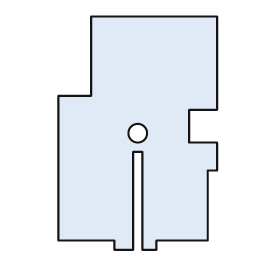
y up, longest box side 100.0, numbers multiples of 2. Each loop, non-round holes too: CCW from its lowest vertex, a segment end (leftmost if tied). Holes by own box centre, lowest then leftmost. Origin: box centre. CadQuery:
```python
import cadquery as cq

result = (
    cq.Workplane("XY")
    .moveTo(-10.0, -50.0)
    .lineTo(-2.0, -50.0)
    .lineTo(-2.0, -8.0)
    .lineTo(2.0, -8.0)
    .lineTo(2.0, -50.0)
    .lineTo(8.0, -50.0)
    .lineTo(8.0, -46.0)
    .lineTo(30.0, -46.0)
    .lineTo(30.0, -16.0)
    .lineTo(34.0, -16.0)
    .lineTo(34.0, -4.0)
    .lineTo(22.0, -4.0)
    .lineTo(22.0, 10.0)
    .lineTo(34.0, 10.0)
    .lineTo(34.0, 50.0)
    .lineTo(-20.0, 50.0)
    .lineTo(-20.0, 16.0)
    .lineTo(-34.0, 16.0)
    .lineTo(-34.0, -46.0)
    .lineTo(-10.0, -46.0)
    .close()
    .moveTo(0.0, 0.0)
    .circle(4.0)
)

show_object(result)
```